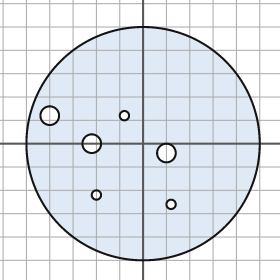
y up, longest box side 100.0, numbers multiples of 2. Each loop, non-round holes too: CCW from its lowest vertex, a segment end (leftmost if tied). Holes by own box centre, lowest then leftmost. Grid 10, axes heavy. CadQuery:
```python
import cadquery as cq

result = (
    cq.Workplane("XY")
    .moveTo(0.0, 0.0)
    .circle(50.0)
    .moveTo(12.0, -26.0)
    .circle(2.0)
    .moveTo(-20.0, -22.0)
    .circle(2.0)
    .moveTo(10.0, -4.0)
    .circle(4.0)
    .moveTo(-22.0, 0.0)
    .circle(4.0)
    .moveTo(-40.0, 12.0)
    .circle(4.0)
    .moveTo(-8.0, 12.0)
    .circle(2.0)
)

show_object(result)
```